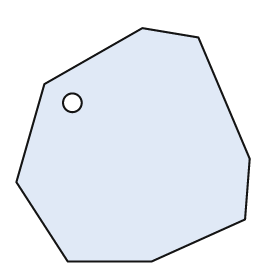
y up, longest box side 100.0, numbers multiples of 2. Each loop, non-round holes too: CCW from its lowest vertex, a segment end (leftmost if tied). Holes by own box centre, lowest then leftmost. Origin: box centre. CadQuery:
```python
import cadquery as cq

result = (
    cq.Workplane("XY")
    .moveTo(-28.0, -50.0)
    .lineTo(8.0, -50.0)
    .lineTo(48.0, -32.0)
    .lineTo(50.0, -6.0)
    .lineTo(28.0, 46.0)
    .lineTo(4.0, 50.0)
    .lineTo(-38.0, 26.0)
    .lineTo(-50.0, -16.0)
    .close()
    .moveTo(-26.0, 18.0)
    .circle(4.0)
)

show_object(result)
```